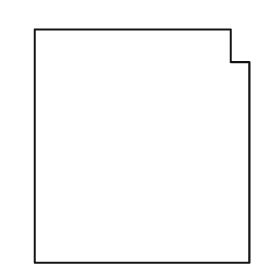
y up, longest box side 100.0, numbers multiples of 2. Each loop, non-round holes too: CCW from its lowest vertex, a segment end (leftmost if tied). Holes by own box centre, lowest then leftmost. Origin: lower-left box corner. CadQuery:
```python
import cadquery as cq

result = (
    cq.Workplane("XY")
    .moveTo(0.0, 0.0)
    .lineTo(92.0, 0.0)
    .lineTo(92.0, 86.0)
    .lineTo(84.0, 86.0)
    .lineTo(84.0, 100.0)
    .lineTo(0.0, 100.0)
    .close()
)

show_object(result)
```